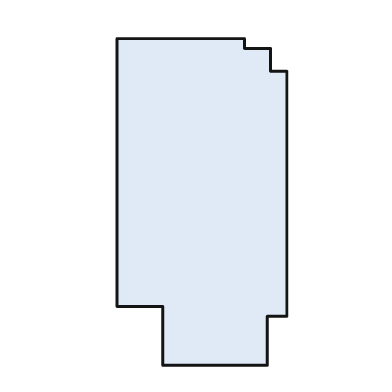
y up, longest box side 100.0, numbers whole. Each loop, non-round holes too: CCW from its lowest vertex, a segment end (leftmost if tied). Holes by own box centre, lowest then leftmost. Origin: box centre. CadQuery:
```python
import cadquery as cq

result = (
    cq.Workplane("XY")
    .moveTo(-12.0, -50.0)
    .lineTo(20.0, -50.0)
    .lineTo(20.0, -35.0)
    .lineTo(26.0, -35.0)
    .lineTo(26.0, 40.0)
    .lineTo(21.0, 40.0)
    .lineTo(21.0, 47.0)
    .lineTo(13.0, 47.0)
    .lineTo(13.0, 50.0)
    .lineTo(-26.0, 50.0)
    .lineTo(-26.0, -32.0)
    .lineTo(-12.0, -32.0)
    .close()
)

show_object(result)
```